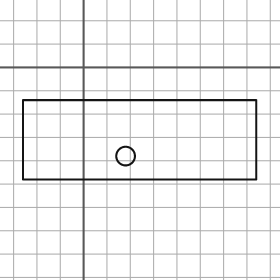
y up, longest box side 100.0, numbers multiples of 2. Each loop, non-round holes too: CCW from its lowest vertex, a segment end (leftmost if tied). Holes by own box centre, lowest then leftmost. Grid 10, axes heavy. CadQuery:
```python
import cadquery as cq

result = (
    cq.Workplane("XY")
    .moveTo(-26.0, -48.0)
    .lineTo(74.0, -48.0)
    .lineTo(74.0, -14.0)
    .lineTo(-26.0, -14.0)
    .close()
    .moveTo(18.0, -38.0)
    .circle(4.0)
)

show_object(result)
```